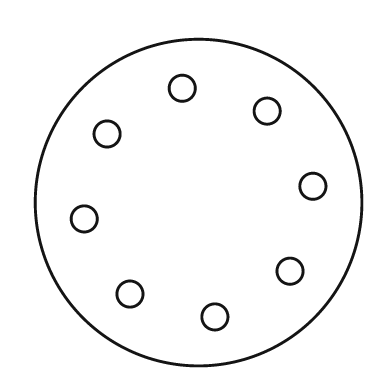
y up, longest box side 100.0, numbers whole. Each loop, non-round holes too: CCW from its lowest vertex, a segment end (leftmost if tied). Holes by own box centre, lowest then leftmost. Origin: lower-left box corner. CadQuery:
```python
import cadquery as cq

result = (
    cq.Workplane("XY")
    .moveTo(50.0, 50.0)
    .circle(50.0)
    .moveTo(55.0, 15.0)
    .circle(4.0)
    .moveTo(29.0, 22.0)
    .circle(4.0)
    .moveTo(78.0, 29.0)
    .circle(4.0)
    .moveTo(15.0, 45.0)
    .circle(4.0)
    .moveTo(85.0, 55.0)
    .circle(4.0)
    .moveTo(22.0, 71.0)
    .circle(4.0)
    .moveTo(71.0, 78.0)
    .circle(4.0)
    .moveTo(45.0, 85.0)
    .circle(4.0)
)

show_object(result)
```